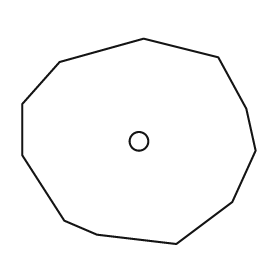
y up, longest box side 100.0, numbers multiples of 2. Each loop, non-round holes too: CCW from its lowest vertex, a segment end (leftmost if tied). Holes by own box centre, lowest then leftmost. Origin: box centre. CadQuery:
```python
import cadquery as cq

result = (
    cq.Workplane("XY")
    .moveTo(16.0, -44.0)
    .lineTo(40.0, -26.0)
    .lineTo(50.0, -4.0)
    .lineTo(46.0, 14.0)
    .lineTo(34.0, 36.0)
    .lineTo(2.0, 44.0)
    .lineTo(-34.0, 34.0)
    .lineTo(-50.0, 16.0)
    .lineTo(-50.0, -6.0)
    .lineTo(-32.0, -34.0)
    .lineTo(-18.0, -40.0)
    .close()
    .moveTo(0.0, 0.0)
    .circle(4.0)
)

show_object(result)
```